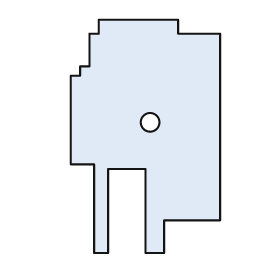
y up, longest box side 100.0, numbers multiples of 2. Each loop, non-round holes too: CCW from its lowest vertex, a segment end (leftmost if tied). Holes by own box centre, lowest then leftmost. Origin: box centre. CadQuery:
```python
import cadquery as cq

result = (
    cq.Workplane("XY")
    .moveTo(-22.0, -50.0)
    .lineTo(-16.0, -50.0)
    .lineTo(-16.0, -14.0)
    .lineTo(0.0, -14.0)
    .lineTo(0.0, -50.0)
    .lineTo(8.0, -50.0)
    .lineTo(8.0, -36.0)
    .lineTo(32.0, -36.0)
    .lineTo(32.0, 44.0)
    .lineTo(14.0, 44.0)
    .lineTo(14.0, 50.0)
    .lineTo(-20.0, 50.0)
    .lineTo(-20.0, 44.0)
    .lineTo(-24.0, 44.0)
    .lineTo(-24.0, 30.0)
    .lineTo(-28.0, 30.0)
    .lineTo(-28.0, 26.0)
    .lineTo(-32.0, 26.0)
    .lineTo(-32.0, -12.0)
    .lineTo(-22.0, -12.0)
    .close()
    .moveTo(2.0, 6.0)
    .circle(4.0)
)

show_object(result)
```